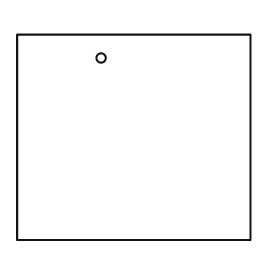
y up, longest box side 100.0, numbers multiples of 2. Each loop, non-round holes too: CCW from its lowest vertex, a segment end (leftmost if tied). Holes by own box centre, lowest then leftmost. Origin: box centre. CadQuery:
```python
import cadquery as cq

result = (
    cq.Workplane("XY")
    .moveTo(-50.0, -44.0)
    .lineTo(50.0, -44.0)
    .lineTo(50.0, 44.0)
    .lineTo(-50.0, 44.0)
    .close()
    .moveTo(-14.0, 34.0)
    .circle(2.0)
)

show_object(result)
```